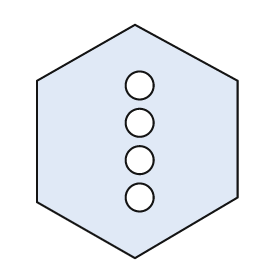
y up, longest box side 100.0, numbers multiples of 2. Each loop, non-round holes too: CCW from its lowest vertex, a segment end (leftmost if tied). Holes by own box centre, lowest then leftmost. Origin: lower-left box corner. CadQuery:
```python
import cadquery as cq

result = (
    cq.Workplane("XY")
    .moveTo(42.0, 0.0)
    .lineTo(86.0, 26.0)
    .lineTo(86.0, 76.0)
    .lineTo(42.0, 100.0)
    .lineTo(0.0, 76.0)
    .lineTo(0.0, 24.0)
    .close()
    .moveTo(44.0, 26.0)
    .circle(6.0)
    .moveTo(44.0, 42.0)
    .circle(6.0)
    .moveTo(44.0, 58.0)
    .circle(6.0)
    .moveTo(44.0, 74.0)
    .circle(6.0)
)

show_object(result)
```